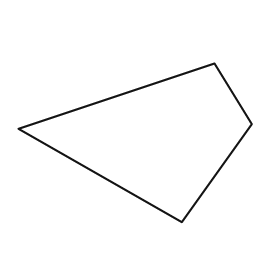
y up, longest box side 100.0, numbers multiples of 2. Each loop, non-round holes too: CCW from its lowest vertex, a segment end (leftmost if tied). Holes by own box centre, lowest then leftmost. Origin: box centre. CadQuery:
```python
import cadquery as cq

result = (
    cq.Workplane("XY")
    .moveTo(20.0, -34.0)
    .lineTo(50.0, 8.0)
    .lineTo(34.0, 34.0)
    .lineTo(-50.0, 6.0)
    .close()
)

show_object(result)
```